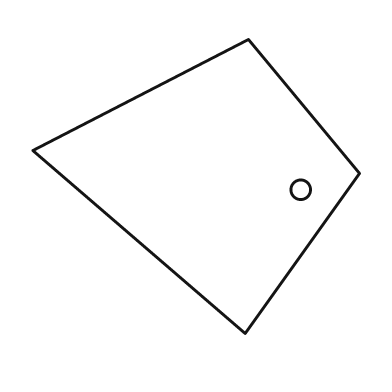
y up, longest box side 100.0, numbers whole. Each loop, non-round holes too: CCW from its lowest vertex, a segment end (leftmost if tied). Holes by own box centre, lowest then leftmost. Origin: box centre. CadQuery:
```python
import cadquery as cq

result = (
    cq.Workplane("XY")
    .moveTo(15.0, -45.0)
    .lineTo(50.0, 4.0)
    .lineTo(16.0, 45.0)
    .lineTo(-50.0, 11.0)
    .close()
    .moveTo(32.0, -1.0)
    .circle(3.0)
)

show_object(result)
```